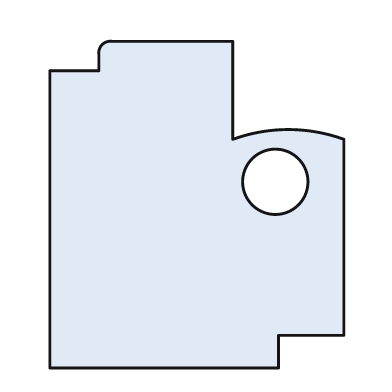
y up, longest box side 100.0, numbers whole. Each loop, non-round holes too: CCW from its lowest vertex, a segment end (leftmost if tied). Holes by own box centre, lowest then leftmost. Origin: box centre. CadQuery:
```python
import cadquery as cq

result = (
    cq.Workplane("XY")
    .moveTo(-45.0, -50.0)
    .lineTo(25.0, -50.0)
    .lineTo(25.0, -40.0)
    .lineTo(45.0, -40.0)
    .lineTo(45.0, 20.0)
    .threePointArc((28.0, 23.0), (11.0, 20.0))
    .lineTo(11.0, 50.0)
    .lineTo(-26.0, 50.0)
    .threePointArc((-29.0, 49.0), (-30.0, 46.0))
    .lineTo(-30.0, 41.0)
    .lineTo(-45.0, 41.0)
    .close()
    .moveTo(24.0, 7.0)
    .circle(10.0)
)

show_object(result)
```